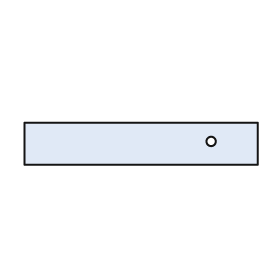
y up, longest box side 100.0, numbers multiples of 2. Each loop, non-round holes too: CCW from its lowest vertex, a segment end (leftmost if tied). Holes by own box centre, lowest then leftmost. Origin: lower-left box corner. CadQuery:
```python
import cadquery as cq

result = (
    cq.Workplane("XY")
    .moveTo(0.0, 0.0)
    .lineTo(100.0, 0.0)
    .lineTo(100.0, 18.0)
    .lineTo(0.0, 18.0)
    .close()
    .moveTo(80.0, 10.0)
    .circle(2.0)
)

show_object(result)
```